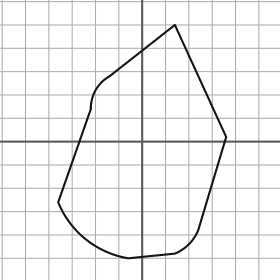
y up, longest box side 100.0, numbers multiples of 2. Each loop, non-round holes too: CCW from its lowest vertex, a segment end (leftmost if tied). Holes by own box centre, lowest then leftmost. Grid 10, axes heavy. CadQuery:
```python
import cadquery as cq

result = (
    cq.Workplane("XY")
    .moveTo(-6.0, -50.0)
    .lineTo(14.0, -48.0)
    .threePointArc((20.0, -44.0), (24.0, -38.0))
    .lineTo(36.0, 2.0)
    .lineTo(14.0, 50.0)
    .lineTo(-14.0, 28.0)
    .threePointArc((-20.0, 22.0), (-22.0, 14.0))
    .lineTo(-36.0, -26.0)
    .threePointArc((-24.0, -42.0), (-6.0, -50.0))
    .close()
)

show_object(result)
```